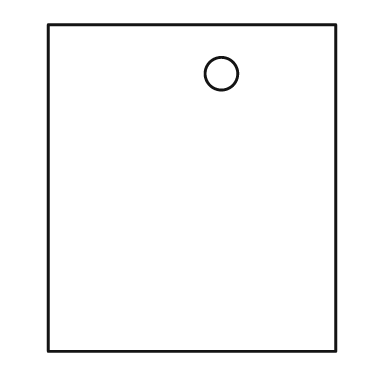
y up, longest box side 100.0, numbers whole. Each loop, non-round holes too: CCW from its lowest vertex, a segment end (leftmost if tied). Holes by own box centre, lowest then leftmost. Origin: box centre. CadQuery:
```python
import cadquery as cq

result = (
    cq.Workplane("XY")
    .moveTo(-44.0, -50.0)
    .lineTo(44.0, -50.0)
    .lineTo(44.0, 50.0)
    .lineTo(-44.0, 50.0)
    .close()
    .moveTo(9.0, 35.0)
    .circle(5.0)
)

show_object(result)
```